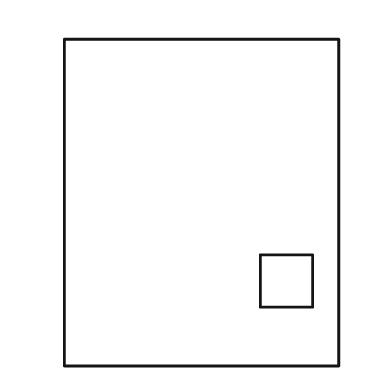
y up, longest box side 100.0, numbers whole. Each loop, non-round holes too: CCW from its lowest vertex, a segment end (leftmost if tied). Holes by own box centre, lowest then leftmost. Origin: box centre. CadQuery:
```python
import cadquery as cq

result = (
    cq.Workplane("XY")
    .moveTo(-42.0, -50.0)
    .lineTo(42.0, -50.0)
    .lineTo(42.0, 50.0)
    .lineTo(-42.0, 50.0)
    .close()
    .moveTo(18.0, -32.0)
    .lineTo(34.0, -32.0)
    .lineTo(34.0, -16.0)
    .lineTo(18.0, -16.0)
    .close()
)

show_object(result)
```